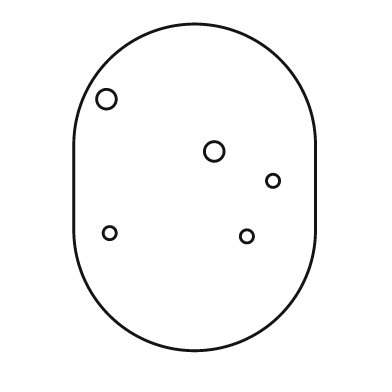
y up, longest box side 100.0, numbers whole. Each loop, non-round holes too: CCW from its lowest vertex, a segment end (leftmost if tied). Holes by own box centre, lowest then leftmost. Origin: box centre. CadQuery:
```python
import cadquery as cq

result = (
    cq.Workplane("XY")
    .moveTo(-37.0, -13.0)
    .threePointArc((0.0, -50.0), (37.0, -13.0))
    .lineTo(37.0, 13.0)
    .threePointArc((0.0, 50.0), (-37.0, 13.0))
    .close()
    .moveTo(16.0, -15.0)
    .circle(2.0)
    .moveTo(-26.0, -14.0)
    .circle(2.0)
    .moveTo(24.0, 2.0)
    .circle(2.0)
    .moveTo(6.0, 11.0)
    .circle(3.0)
    .moveTo(-27.0, 27.0)
    .circle(3.0)
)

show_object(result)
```